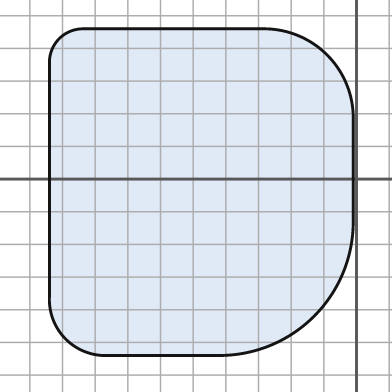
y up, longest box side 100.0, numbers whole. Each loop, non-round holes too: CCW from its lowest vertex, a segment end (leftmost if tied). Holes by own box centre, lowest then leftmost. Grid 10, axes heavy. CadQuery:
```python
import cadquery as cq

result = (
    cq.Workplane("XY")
    .moveTo(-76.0, -54.0)
    .lineTo(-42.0, -54.0)
    .threePointArc((-13.0, -42.0), (-1.0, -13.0))
    .lineTo(-1.0, 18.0)
    .threePointArc((-9.0, 38.0), (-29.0, 46.0))
    .lineTo(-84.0, 46.0)
    .threePointArc((-91.0, 43.0), (-94.0, 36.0))
    .lineTo(-94.0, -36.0)
    .threePointArc((-89.0, -49.0), (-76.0, -54.0))
    .close()
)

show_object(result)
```